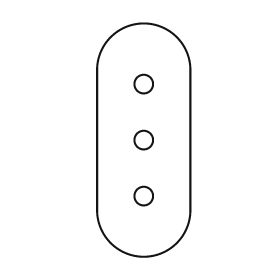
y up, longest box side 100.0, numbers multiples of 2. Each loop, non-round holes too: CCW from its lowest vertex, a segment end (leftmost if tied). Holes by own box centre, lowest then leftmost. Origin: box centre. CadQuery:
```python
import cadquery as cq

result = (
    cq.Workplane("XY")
    .moveTo(-20.0, -30.0)
    .threePointArc((0.0, -50.0), (20.0, -30.0))
    .lineTo(20.0, 30.0)
    .threePointArc((0.0, 50.0), (-20.0, 30.0))
    .close()
    .moveTo(0.0, -24.0)
    .circle(4.0)
    .moveTo(0.0, 0.0)
    .circle(4.0)
    .moveTo(0.0, 24.0)
    .circle(4.0)
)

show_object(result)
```